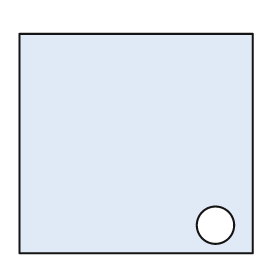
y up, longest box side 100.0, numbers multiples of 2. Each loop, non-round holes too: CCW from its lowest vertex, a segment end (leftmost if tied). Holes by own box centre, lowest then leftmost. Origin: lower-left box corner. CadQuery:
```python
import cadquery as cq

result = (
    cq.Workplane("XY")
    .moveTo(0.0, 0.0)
    .lineTo(100.0, 0.0)
    .lineTo(100.0, 94.0)
    .lineTo(0.0, 94.0)
    .close()
    .moveTo(84.0, 12.0)
    .circle(8.0)
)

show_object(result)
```